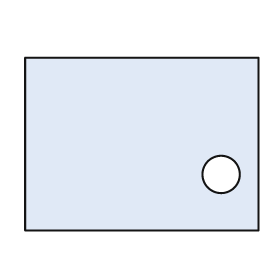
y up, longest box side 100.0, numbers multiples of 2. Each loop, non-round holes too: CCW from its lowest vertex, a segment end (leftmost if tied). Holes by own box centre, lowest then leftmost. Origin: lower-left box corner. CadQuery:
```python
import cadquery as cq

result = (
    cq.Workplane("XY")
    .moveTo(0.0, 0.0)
    .lineTo(100.0, 0.0)
    .lineTo(100.0, 74.0)
    .lineTo(0.0, 74.0)
    .close()
    .moveTo(84.0, 24.0)
    .circle(8.0)
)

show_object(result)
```